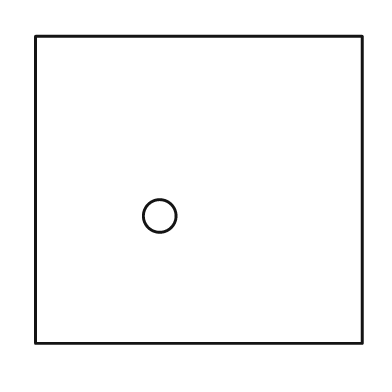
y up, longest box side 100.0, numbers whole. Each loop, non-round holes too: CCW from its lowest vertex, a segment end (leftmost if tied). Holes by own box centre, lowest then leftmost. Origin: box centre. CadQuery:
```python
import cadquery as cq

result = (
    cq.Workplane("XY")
    .moveTo(-50.0, -47.0)
    .lineTo(50.0, -47.0)
    .lineTo(50.0, 47.0)
    .lineTo(-50.0, 47.0)
    .close()
    .moveTo(-12.0, -8.0)
    .circle(5.0)
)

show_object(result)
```